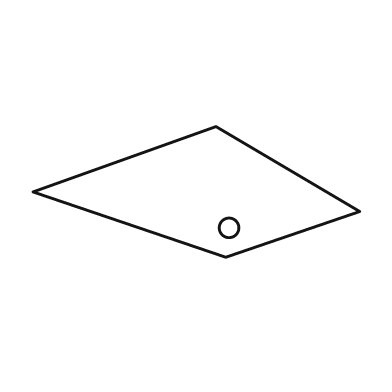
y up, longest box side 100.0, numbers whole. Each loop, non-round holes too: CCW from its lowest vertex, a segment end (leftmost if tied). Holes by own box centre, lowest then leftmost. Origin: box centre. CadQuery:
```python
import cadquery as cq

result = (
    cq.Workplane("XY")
    .moveTo(9.0, -20.0)
    .lineTo(50.0, -6.0)
    .lineTo(6.0, 20.0)
    .lineTo(-50.0, 0.0)
    .close()
    .moveTo(10.0, -11.0)
    .circle(3.0)
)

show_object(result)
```